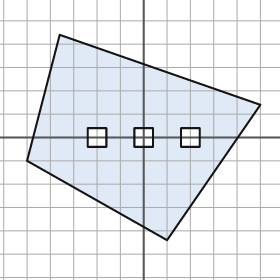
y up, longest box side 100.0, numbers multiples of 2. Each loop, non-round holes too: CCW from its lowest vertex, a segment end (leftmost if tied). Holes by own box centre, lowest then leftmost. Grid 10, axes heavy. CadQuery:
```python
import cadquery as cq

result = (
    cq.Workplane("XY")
    .moveTo(10.0, -44.0)
    .lineTo(50.0, 14.0)
    .lineTo(-36.0, 44.0)
    .lineTo(-50.0, -10.0)
    .close()
    .moveTo(-24.0, -4.0)
    .lineTo(-16.0, -4.0)
    .lineTo(-16.0, 4.0)
    .lineTo(-24.0, 4.0)
    .close()
    .moveTo(-4.0, -4.0)
    .lineTo(4.0, -4.0)
    .lineTo(4.0, 4.0)
    .lineTo(-4.0, 4.0)
    .close()
    .moveTo(16.0, -4.0)
    .lineTo(24.0, -4.0)
    .lineTo(24.0, 4.0)
    .lineTo(16.0, 4.0)
    .close()
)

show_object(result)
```